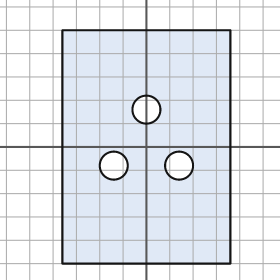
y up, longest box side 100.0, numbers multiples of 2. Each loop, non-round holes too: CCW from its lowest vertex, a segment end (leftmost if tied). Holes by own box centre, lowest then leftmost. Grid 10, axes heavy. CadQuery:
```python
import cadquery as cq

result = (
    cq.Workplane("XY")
    .moveTo(-36.0, -50.0)
    .lineTo(36.0, -50.0)
    .lineTo(36.0, 50.0)
    .lineTo(-36.0, 50.0)
    .close()
    .moveTo(-14.0, -8.0)
    .circle(6.0)
    .moveTo(14.0, -8.0)
    .circle(6.0)
    .moveTo(0.0, 16.0)
    .circle(6.0)
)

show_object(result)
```